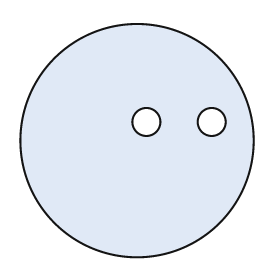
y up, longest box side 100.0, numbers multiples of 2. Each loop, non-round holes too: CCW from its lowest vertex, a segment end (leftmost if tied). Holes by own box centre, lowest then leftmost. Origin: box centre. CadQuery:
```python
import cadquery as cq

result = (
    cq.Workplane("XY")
    .moveTo(0.0, 0.0)
    .circle(50.0)
    .moveTo(4.0, 8.0)
    .circle(6.0)
    .moveTo(32.0, 8.0)
    .circle(6.0)
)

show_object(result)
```